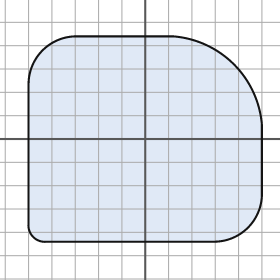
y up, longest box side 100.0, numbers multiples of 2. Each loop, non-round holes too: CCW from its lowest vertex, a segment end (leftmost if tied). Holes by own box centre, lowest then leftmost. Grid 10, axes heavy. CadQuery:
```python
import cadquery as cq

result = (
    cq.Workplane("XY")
    .moveTo(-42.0, -44.0)
    .lineTo(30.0, -44.0)
    .threePointArc((44.0, -38.0), (50.0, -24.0))
    .lineTo(50.0, 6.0)
    .threePointArc((38.0, 32.0), (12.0, 44.0))
    .lineTo(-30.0, 44.0)
    .threePointArc((-44.0, 38.0), (-50.0, 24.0))
    .lineTo(-50.0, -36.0)
    .threePointArc((-48.0, -42.0), (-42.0, -44.0))
    .close()
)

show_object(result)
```